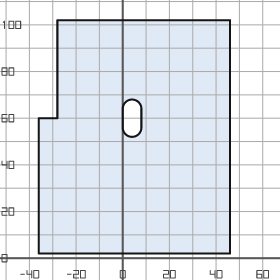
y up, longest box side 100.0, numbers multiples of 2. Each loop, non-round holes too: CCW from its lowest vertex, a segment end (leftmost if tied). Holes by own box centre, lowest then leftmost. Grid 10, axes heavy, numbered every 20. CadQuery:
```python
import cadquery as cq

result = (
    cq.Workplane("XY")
    .moveTo(-36.0, 2.0)
    .lineTo(46.0, 2.0)
    .lineTo(46.0, 102.0)
    .lineTo(-28.0, 102.0)
    .lineTo(-28.0, 60.0)
    .lineTo(-36.0, 60.0)
    .close()
    .moveTo(0.0, 56.0)
    .threePointArc((4.0, 52.0), (8.0, 56.0))
    .lineTo(8.0, 64.0)
    .threePointArc((4.0, 68.0), (0.0, 64.0))
    .close()
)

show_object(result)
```